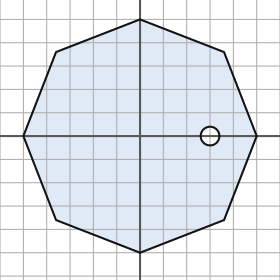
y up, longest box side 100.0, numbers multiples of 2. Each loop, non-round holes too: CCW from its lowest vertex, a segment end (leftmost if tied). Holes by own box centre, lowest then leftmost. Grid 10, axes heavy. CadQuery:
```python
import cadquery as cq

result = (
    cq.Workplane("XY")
    .moveTo(0.0, -50.0)
    .lineTo(36.0, -36.0)
    .lineTo(50.0, 0.0)
    .lineTo(36.0, 36.0)
    .lineTo(0.0, 50.0)
    .lineTo(-36.0, 36.0)
    .lineTo(-50.0, 0.0)
    .lineTo(-36.0, -36.0)
    .close()
    .moveTo(30.0, 0.0)
    .circle(4.0)
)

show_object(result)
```